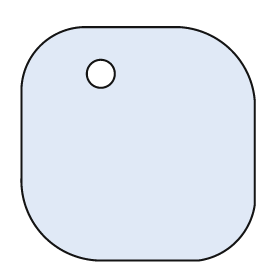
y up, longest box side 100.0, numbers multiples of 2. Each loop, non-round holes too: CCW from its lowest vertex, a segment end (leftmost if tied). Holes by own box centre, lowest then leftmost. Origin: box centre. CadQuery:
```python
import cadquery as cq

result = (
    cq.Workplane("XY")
    .moveTo(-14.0, -50.0)
    .lineTo(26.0, -50.0)
    .threePointArc((42.0, -42.0), (50.0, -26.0))
    .lineTo(50.0, 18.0)
    .threePointArc((40.0, 40.0), (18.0, 50.0))
    .lineTo(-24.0, 50.0)
    .threePointArc((-42.0, 42.0), (-50.0, 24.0))
    .lineTo(-50.0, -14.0)
    .threePointArc((-40.0, -40.0), (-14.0, -50.0))
    .close()
    .moveTo(-16.0, 30.0)
    .circle(6.0)
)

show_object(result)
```